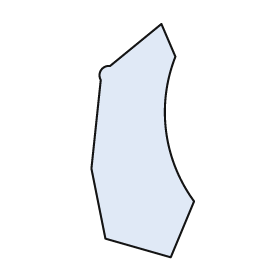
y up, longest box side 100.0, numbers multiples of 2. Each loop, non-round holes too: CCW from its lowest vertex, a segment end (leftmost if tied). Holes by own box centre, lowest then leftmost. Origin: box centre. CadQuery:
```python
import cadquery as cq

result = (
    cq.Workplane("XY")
    .moveTo(12.0, -50.0)
    .lineTo(22.0, -26.0)
    .threePointArc((10.0, 4.0), (14.0, 36.0))
    .lineTo(8.0, 50.0)
    .lineTo(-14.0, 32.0)
    .threePointArc((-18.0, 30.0), (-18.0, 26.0))
    .lineTo(-22.0, -12.0)
    .lineTo(-16.0, -42.0)
    .close()
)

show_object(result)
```